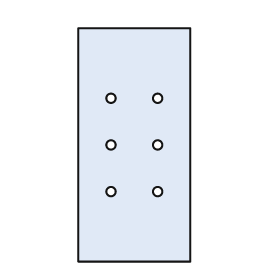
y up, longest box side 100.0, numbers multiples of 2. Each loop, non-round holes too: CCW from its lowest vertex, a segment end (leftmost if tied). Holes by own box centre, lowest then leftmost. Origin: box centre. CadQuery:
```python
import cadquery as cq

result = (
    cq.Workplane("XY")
    .moveTo(-24.0, -50.0)
    .lineTo(24.0, -50.0)
    .lineTo(24.0, 50.0)
    .lineTo(-24.0, 50.0)
    .close()
    .moveTo(-10.0, -20.0)
    .circle(2.0)
    .moveTo(10.0, -20.0)
    .circle(2.0)
    .moveTo(-10.0, 0.0)
    .circle(2.0)
    .moveTo(10.0, 0.0)
    .circle(2.0)
    .moveTo(-10.0, 20.0)
    .circle(2.0)
    .moveTo(10.0, 20.0)
    .circle(2.0)
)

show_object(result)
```